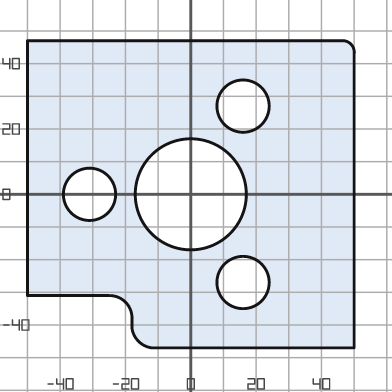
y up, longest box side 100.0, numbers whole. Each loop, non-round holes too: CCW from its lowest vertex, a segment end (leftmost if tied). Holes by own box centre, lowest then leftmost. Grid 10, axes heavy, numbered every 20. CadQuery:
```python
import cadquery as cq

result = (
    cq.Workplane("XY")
    .moveTo(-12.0, -47.0)
    .lineTo(50.0, -47.0)
    .lineTo(50.0, 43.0)
    .threePointArc((49.0, 46.0), (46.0, 47.0))
    .lineTo(-50.0, 47.0)
    .lineTo(-50.0, -31.0)
    .lineTo(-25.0, -31.0)
    .threePointArc((-20.0, -33.0), (-18.0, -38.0))
    .lineTo(-18.0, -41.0)
    .threePointArc((-16.0, -45.0), (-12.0, -47.0))
    .close()
    .moveTo(16.0, -27.0)
    .circle(8.0)
    .moveTo(-31.0, 0.0)
    .circle(8.0)
    .moveTo(0.0, 0.0)
    .circle(17.0)
    .moveTo(16.0, 27.0)
    .circle(8.0)
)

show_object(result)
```